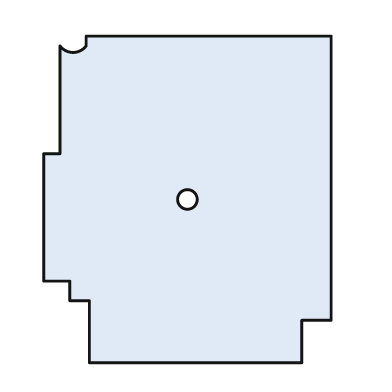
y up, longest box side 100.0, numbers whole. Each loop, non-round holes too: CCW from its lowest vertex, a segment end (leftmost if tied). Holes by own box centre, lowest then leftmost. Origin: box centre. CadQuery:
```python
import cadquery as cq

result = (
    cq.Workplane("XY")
    .moveTo(-30.0, -50.0)
    .lineTo(35.0, -50.0)
    .lineTo(35.0, -37.0)
    .lineTo(44.0, -37.0)
    .lineTo(44.0, 50.0)
    .lineTo(-31.0, 50.0)
    .lineTo(-31.0, 47.0)
    .threePointArc((-35.0, 45.0), (-39.0, 47.0))
    .lineTo(-39.0, 14.0)
    .lineTo(-44.0, 14.0)
    .lineTo(-44.0, -25.0)
    .lineTo(-36.0, -25.0)
    .lineTo(-36.0, -31.0)
    .lineTo(-30.0, -31.0)
    .close()
    .moveTo(0.0, 0.0)
    .circle(3.0)
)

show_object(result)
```